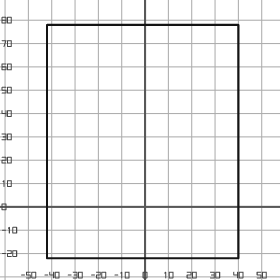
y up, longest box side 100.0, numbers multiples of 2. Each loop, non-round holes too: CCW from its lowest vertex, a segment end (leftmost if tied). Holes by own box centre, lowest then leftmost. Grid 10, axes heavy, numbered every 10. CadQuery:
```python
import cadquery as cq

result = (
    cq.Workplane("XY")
    .moveTo(-42.0, -22.0)
    .lineTo(40.0, -22.0)
    .lineTo(40.0, 78.0)
    .lineTo(-42.0, 78.0)
    .close()
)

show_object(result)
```